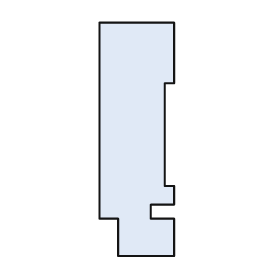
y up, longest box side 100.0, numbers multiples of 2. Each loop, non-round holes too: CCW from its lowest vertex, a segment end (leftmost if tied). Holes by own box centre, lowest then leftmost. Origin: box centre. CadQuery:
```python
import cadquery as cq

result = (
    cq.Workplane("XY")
    .moveTo(-8.0, -50.0)
    .lineTo(16.0, -50.0)
    .lineTo(16.0, -34.0)
    .lineTo(6.0, -34.0)
    .lineTo(6.0, -28.0)
    .lineTo(16.0, -28.0)
    .lineTo(16.0, -20.0)
    .lineTo(12.0, -20.0)
    .lineTo(12.0, 24.0)
    .lineTo(16.0, 24.0)
    .lineTo(16.0, 50.0)
    .lineTo(-16.0, 50.0)
    .lineTo(-16.0, -34.0)
    .lineTo(-8.0, -34.0)
    .close()
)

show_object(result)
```